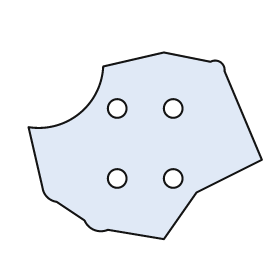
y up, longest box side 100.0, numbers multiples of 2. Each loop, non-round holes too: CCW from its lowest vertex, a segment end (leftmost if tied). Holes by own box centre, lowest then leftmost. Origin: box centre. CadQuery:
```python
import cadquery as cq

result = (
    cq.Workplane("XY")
    .moveTo(8.0, -40.0)
    .lineTo(22.0, -20.0)
    .lineTo(50.0, -6.0)
    .lineTo(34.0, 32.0)
    .threePointArc((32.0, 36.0), (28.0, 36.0))
    .lineTo(8.0, 40.0)
    .lineTo(-18.0, 34.0)
    .threePointArc((-28.0, 14.0), (-50.0, 8.0))
    .lineTo(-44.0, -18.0)
    .threePointArc((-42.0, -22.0), (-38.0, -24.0))
    .lineTo(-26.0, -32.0)
    .threePointArc((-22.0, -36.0), (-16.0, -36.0))
    .close()
    .moveTo(-12.0, -14.0)
    .circle(4.0)
    .moveTo(12.0, -14.0)
    .circle(4.0)
    .moveTo(-12.0, 16.0)
    .circle(4.0)
    .moveTo(12.0, 16.0)
    .circle(4.0)
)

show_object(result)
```